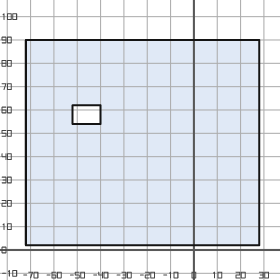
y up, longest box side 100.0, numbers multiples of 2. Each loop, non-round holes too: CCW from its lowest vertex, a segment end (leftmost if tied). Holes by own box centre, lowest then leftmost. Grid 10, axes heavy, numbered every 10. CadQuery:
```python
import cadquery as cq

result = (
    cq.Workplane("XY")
    .moveTo(-72.0, 2.0)
    .lineTo(28.0, 2.0)
    .lineTo(28.0, 90.0)
    .lineTo(-72.0, 90.0)
    .close()
    .moveTo(-52.0, 54.0)
    .lineTo(-40.0, 54.0)
    .lineTo(-40.0, 62.0)
    .lineTo(-52.0, 62.0)
    .close()
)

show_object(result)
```